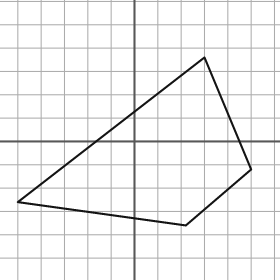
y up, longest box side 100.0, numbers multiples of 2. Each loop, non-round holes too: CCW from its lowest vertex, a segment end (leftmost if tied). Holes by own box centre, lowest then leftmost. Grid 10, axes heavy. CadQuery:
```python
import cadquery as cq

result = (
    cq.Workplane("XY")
    .moveTo(22.0, -36.0)
    .lineTo(50.0, -12.0)
    .lineTo(30.0, 36.0)
    .lineTo(-50.0, -26.0)
    .close()
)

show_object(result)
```